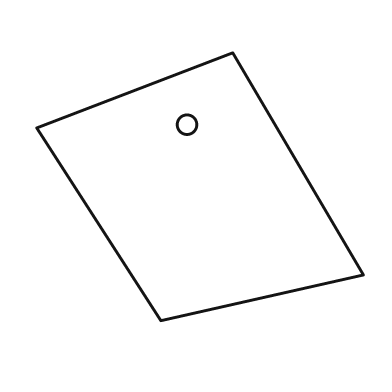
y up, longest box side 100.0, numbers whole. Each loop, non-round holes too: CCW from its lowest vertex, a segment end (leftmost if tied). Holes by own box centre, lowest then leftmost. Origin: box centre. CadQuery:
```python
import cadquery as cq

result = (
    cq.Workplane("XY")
    .moveTo(-12.0, -41.0)
    .lineTo(50.0, -27.0)
    .lineTo(10.0, 41.0)
    .lineTo(-50.0, 18.0)
    .close()
    .moveTo(-4.0, 19.0)
    .circle(3.0)
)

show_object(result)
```